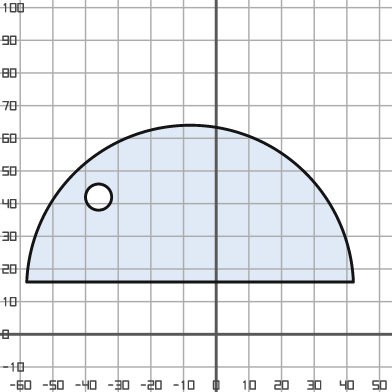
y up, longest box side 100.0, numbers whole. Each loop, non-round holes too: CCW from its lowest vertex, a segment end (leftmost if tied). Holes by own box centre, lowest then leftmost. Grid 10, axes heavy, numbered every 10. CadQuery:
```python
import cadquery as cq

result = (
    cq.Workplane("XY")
    .moveTo(-58.0, 16.0)
    .lineTo(42.0, 16.0)
    .threePointArc((-8.0, 64.0), (-58.0, 16.0))
    .close()
    .moveTo(-36.0, 42.0)
    .circle(4.0)
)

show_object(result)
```